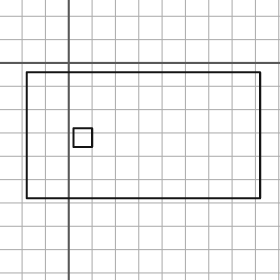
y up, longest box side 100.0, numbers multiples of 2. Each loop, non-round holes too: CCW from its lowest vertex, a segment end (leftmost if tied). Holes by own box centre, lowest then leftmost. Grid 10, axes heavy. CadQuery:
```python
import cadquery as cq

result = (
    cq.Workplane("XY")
    .moveTo(-18.0, -58.0)
    .lineTo(82.0, -58.0)
    .lineTo(82.0, -4.0)
    .lineTo(-18.0, -4.0)
    .close()
    .moveTo(2.0, -36.0)
    .lineTo(10.0, -36.0)
    .lineTo(10.0, -28.0)
    .lineTo(2.0, -28.0)
    .close()
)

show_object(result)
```